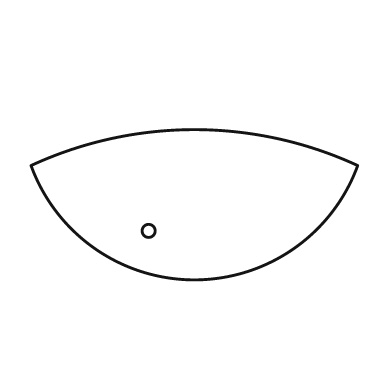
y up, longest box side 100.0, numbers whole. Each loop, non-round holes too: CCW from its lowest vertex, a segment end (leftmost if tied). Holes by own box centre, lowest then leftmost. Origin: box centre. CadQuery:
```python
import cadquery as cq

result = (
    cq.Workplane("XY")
    .moveTo(-50.0, 12.0)
    .threePointArc((0.0, -23.0), (50.0, 12.0))
    .threePointArc((0.0, 23.0), (-50.0, 12.0))
    .close()
    .moveTo(-14.0, -8.0)
    .circle(2.0)
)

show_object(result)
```